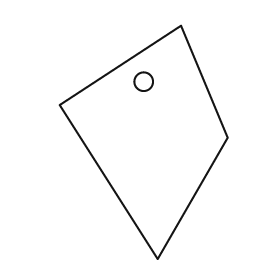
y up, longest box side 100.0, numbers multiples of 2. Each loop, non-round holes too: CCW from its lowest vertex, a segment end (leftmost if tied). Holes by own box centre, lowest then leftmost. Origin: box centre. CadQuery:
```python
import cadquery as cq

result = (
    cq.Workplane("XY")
    .moveTo(6.0, -50.0)
    .lineTo(36.0, 2.0)
    .lineTo(16.0, 50.0)
    .lineTo(-36.0, 16.0)
    .close()
    .moveTo(0.0, 26.0)
    .circle(4.0)
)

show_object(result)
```